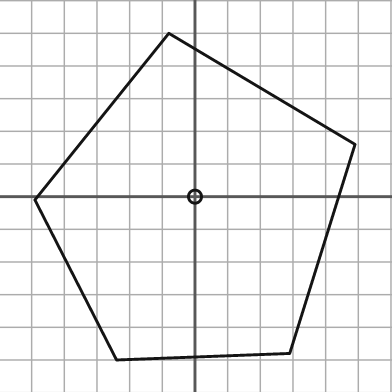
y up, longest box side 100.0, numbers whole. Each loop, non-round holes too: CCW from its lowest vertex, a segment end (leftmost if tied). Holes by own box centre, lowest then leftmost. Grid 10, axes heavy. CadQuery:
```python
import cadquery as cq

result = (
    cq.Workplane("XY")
    .moveTo(-24.0, -50.0)
    .lineTo(29.0, -48.0)
    .lineTo(49.0, 16.0)
    .lineTo(-8.0, 50.0)
    .lineTo(-49.0, -1.0)
    .close()
    .moveTo(0.0, 0.0)
    .circle(2.0)
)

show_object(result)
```